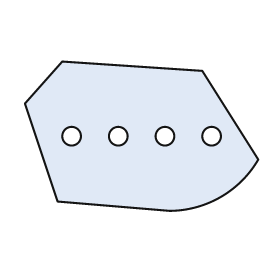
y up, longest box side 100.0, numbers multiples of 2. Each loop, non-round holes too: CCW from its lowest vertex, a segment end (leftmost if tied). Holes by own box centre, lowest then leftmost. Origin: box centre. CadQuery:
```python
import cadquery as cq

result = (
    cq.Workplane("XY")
    .moveTo(12.0, -32.0)
    .threePointArc((34.0, -26.0), (50.0, -10.0))
    .lineTo(26.0, 28.0)
    .lineTo(-34.0, 32.0)
    .lineTo(-50.0, 14.0)
    .lineTo(-36.0, -28.0)
    .close()
    .moveTo(-30.0, 0.0)
    .circle(4.0)
    .moveTo(-10.0, 0.0)
    .circle(4.0)
    .moveTo(10.0, 0.0)
    .circle(4.0)
    .moveTo(30.0, 0.0)
    .circle(4.0)
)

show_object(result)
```